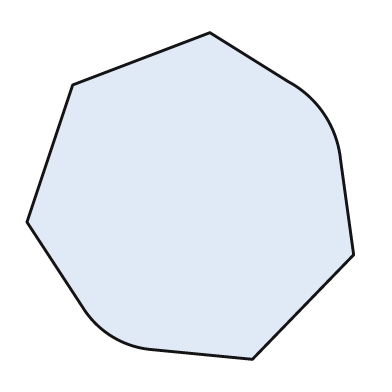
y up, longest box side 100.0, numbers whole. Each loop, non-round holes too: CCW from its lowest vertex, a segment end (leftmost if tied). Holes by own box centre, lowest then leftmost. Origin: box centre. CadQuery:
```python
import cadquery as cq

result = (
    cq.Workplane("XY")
    .moveTo(19.0, -50.0)
    .lineTo(50.0, -18.0)
    .lineTo(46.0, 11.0)
    .threePointArc((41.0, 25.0), (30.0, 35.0))
    .lineTo(6.0, 50.0)
    .lineTo(-36.0, 34.0)
    .lineTo(-50.0, -8.0)
    .lineTo(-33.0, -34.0)
    .threePointArc((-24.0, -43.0), (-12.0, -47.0))
    .close()
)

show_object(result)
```